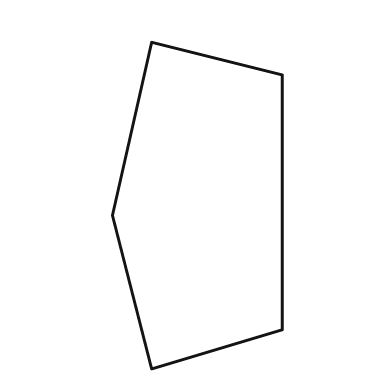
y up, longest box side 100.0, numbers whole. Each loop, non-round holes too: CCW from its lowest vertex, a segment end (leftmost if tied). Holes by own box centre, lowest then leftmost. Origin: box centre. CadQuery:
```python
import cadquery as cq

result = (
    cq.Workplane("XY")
    .moveTo(-14.0, -50.0)
    .lineTo(26.0, -38.0)
    .lineTo(26.0, 40.0)
    .lineTo(-14.0, 50.0)
    .lineTo(-26.0, -3.0)
    .close()
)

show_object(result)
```